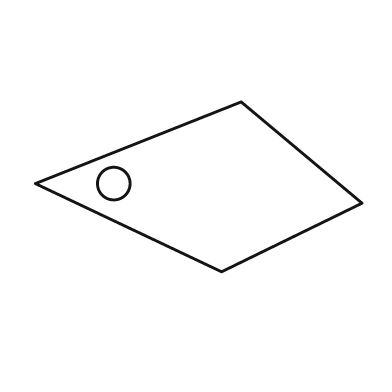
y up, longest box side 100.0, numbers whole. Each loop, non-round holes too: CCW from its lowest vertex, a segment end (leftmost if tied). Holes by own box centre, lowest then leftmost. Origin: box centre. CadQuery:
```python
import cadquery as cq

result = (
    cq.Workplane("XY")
    .moveTo(7.0, -26.0)
    .lineTo(50.0, -5.0)
    .lineTo(13.0, 26.0)
    .lineTo(-50.0, 1.0)
    .close()
    .moveTo(-26.0, 1.0)
    .circle(5.0)
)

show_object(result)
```